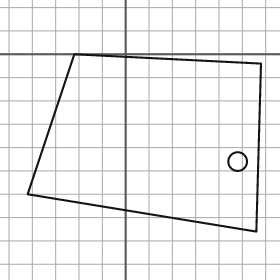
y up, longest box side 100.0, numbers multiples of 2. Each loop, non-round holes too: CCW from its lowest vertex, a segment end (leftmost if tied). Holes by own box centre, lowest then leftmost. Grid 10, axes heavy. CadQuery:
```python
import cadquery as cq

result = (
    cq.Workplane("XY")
    .moveTo(56.0, -76.0)
    .lineTo(58.0, -4.0)
    .lineTo(-22.0, 0.0)
    .lineTo(-42.0, -60.0)
    .close()
    .moveTo(48.0, -46.0)
    .circle(4.0)
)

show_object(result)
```